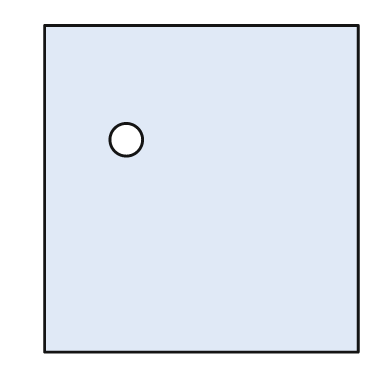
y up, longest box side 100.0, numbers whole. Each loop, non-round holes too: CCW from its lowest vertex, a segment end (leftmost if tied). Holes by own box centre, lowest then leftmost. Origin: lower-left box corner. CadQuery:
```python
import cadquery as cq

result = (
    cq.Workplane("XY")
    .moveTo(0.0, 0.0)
    .lineTo(96.0, 0.0)
    .lineTo(96.0, 100.0)
    .lineTo(0.0, 100.0)
    .close()
    .moveTo(25.0, 65.0)
    .circle(5.0)
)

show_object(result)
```